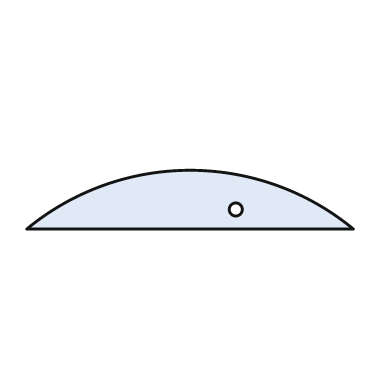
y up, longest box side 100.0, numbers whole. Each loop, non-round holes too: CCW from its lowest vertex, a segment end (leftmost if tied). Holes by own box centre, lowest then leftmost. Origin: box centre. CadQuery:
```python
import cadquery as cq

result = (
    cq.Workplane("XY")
    .moveTo(-50.0, -9.0)
    .lineTo(50.0, -9.0)
    .threePointArc((0.0, 9.0), (-50.0, -9.0))
    .close()
    .moveTo(14.0, -3.0)
    .circle(2.0)
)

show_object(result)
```